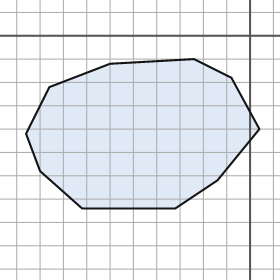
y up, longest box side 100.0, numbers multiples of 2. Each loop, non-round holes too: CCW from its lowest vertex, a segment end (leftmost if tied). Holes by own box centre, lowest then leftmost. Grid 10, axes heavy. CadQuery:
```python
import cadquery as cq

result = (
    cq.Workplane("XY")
    .moveTo(-72.0, -74.0)
    .lineTo(-32.0, -74.0)
    .lineTo(-14.0, -62.0)
    .lineTo(4.0, -40.0)
    .lineTo(-8.0, -18.0)
    .lineTo(-24.0, -10.0)
    .lineTo(-60.0, -12.0)
    .lineTo(-86.0, -22.0)
    .lineTo(-96.0, -42.0)
    .lineTo(-90.0, -58.0)
    .close()
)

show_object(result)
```